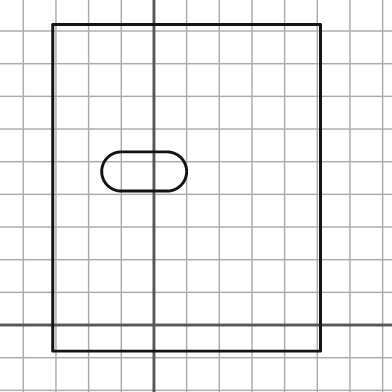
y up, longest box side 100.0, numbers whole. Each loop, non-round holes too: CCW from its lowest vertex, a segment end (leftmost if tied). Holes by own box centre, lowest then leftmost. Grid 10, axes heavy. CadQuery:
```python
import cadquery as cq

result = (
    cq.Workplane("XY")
    .moveTo(-31.0, -8.0)
    .lineTo(51.0, -8.0)
    .lineTo(51.0, 92.0)
    .lineTo(-31.0, 92.0)
    .close()
    .moveTo(-10.0, 41.0)
    .lineTo(4.0, 41.0)
    .threePointArc((10.0, 47.0), (4.0, 53.0))
    .lineTo(-10.0, 53.0)
    .threePointArc((-16.0, 47.0), (-10.0, 41.0))
    .close()
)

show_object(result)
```